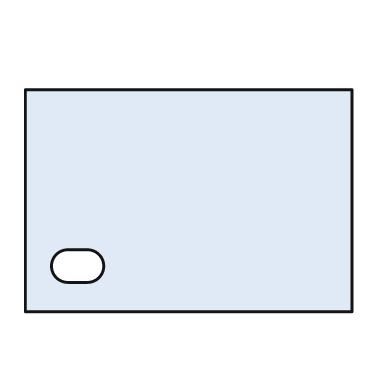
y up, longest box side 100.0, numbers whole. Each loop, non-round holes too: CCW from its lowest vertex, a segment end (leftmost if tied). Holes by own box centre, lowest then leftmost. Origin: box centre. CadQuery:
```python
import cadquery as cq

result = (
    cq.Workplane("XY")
    .moveTo(-50.0, -34.0)
    .lineTo(50.0, -34.0)
    .lineTo(50.0, 34.0)
    .lineTo(-50.0, 34.0)
    .close()
    .moveTo(-37.0, -25.0)
    .lineTo(-31.0, -25.0)
    .threePointArc((-26.0, -20.0), (-31.0, -15.0))
    .lineTo(-37.0, -15.0)
    .threePointArc((-42.0, -20.0), (-37.0, -25.0))
    .close()
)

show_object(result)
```